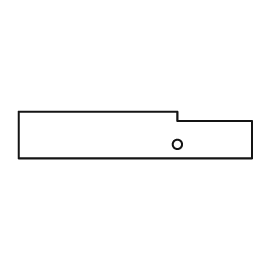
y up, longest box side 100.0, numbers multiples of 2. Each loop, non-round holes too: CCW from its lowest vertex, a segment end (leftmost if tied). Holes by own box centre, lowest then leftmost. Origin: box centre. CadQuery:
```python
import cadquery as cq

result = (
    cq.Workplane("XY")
    .moveTo(-50.0, -10.0)
    .lineTo(50.0, -10.0)
    .lineTo(50.0, 6.0)
    .lineTo(18.0, 6.0)
    .lineTo(18.0, 10.0)
    .lineTo(-50.0, 10.0)
    .close()
    .moveTo(18.0, -4.0)
    .circle(2.0)
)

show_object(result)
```